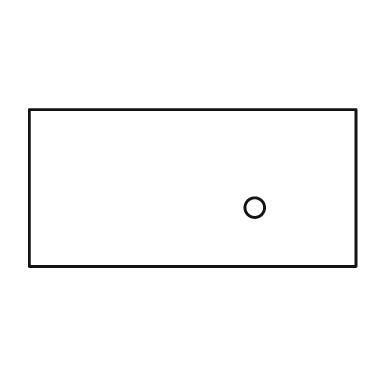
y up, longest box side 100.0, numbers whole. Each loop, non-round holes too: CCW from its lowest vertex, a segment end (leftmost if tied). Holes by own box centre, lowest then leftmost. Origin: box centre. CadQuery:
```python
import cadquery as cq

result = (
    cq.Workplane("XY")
    .moveTo(-50.0, -24.0)
    .lineTo(50.0, -24.0)
    .lineTo(50.0, 24.0)
    .lineTo(-50.0, 24.0)
    .close()
    .moveTo(19.0, -6.0)
    .circle(3.0)
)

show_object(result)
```